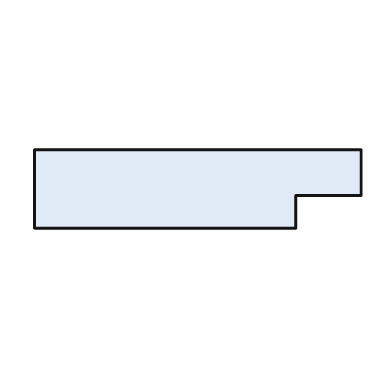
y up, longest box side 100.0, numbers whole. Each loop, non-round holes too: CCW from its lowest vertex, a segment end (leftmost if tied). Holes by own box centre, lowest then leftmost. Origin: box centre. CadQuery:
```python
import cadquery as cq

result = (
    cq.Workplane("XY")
    .moveTo(-50.0, -12.0)
    .lineTo(30.0, -12.0)
    .lineTo(30.0, -2.0)
    .lineTo(50.0, -2.0)
    .lineTo(50.0, 12.0)
    .lineTo(-50.0, 12.0)
    .close()
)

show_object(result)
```